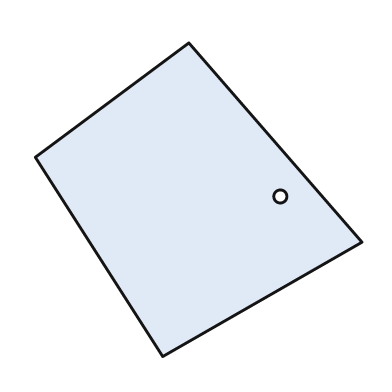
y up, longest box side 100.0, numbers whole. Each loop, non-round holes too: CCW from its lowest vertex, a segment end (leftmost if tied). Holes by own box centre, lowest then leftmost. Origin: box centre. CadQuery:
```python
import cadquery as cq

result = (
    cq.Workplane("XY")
    .moveTo(-11.0, -48.0)
    .lineTo(50.0, -13.0)
    .lineTo(-3.0, 48.0)
    .lineTo(-50.0, 13.0)
    .close()
    .moveTo(25.0, 1.0)
    .circle(2.0)
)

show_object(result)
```